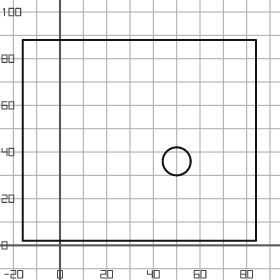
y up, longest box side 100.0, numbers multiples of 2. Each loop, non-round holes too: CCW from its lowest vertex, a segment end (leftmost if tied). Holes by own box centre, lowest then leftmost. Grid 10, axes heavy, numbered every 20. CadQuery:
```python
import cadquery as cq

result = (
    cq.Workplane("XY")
    .moveTo(-16.0, 2.0)
    .lineTo(84.0, 2.0)
    .lineTo(84.0, 88.0)
    .lineTo(-16.0, 88.0)
    .close()
    .moveTo(50.0, 36.0)
    .circle(6.0)
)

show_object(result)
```